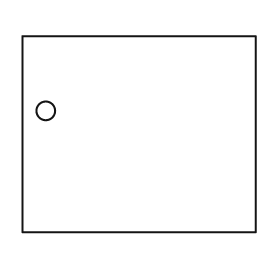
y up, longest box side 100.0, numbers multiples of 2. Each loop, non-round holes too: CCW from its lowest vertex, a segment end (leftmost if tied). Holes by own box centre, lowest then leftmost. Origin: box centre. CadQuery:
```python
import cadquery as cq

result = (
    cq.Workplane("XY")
    .moveTo(-50.0, -42.0)
    .lineTo(50.0, -42.0)
    .lineTo(50.0, 42.0)
    .lineTo(-50.0, 42.0)
    .close()
    .moveTo(-40.0, 10.0)
    .circle(4.0)
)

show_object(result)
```